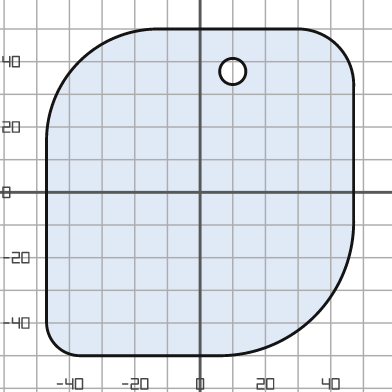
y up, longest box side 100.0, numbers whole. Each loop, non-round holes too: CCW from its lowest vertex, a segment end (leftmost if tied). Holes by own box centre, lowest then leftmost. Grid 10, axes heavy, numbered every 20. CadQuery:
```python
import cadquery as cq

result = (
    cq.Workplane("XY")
    .moveTo(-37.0, -50.0)
    .lineTo(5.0, -50.0)
    .threePointArc((35.0, -38.0), (47.0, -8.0))
    .lineTo(47.0, 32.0)
    .threePointArc((42.0, 45.0), (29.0, 50.0))
    .lineTo(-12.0, 50.0)
    .threePointArc((-37.0, 40.0), (-47.0, 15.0))
    .lineTo(-47.0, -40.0)
    .threePointArc((-44.0, -47.0), (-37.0, -50.0))
    .close()
    .moveTo(10.0, 37.0)
    .circle(4.0)
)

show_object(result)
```